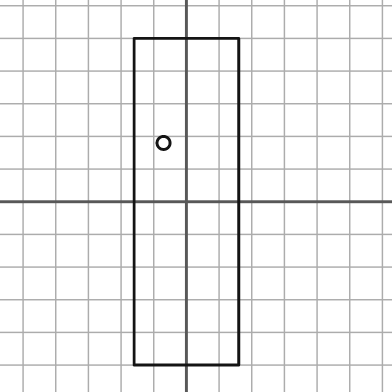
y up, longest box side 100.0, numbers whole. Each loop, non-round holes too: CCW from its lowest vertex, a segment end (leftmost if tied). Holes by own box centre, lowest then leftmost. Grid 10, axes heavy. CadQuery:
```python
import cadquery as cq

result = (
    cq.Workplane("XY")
    .moveTo(-16.0, -50.0)
    .lineTo(16.0, -50.0)
    .lineTo(16.0, 50.0)
    .lineTo(-16.0, 50.0)
    .close()
    .moveTo(-7.0, 18.0)
    .circle(2.0)
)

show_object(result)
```